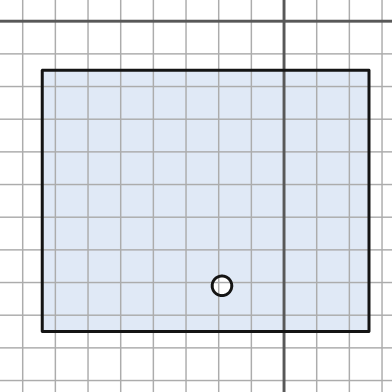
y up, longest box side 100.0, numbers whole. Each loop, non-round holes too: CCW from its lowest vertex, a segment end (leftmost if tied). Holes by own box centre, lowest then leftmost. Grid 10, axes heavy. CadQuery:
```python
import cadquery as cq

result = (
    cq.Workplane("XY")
    .moveTo(-74.0, -95.0)
    .lineTo(26.0, -95.0)
    .lineTo(26.0, -15.0)
    .lineTo(-74.0, -15.0)
    .close()
    .moveTo(-19.0, -81.0)
    .circle(3.0)
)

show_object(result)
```